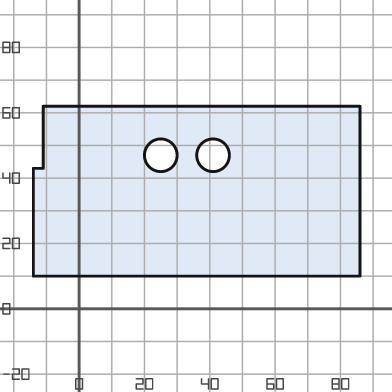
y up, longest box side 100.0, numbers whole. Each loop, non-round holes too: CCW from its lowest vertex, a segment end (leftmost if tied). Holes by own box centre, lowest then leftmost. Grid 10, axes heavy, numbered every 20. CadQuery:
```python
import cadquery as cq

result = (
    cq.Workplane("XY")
    .moveTo(-14.0, 10.0)
    .lineTo(86.0, 10.0)
    .lineTo(86.0, 62.0)
    .lineTo(-11.0, 62.0)
    .lineTo(-11.0, 43.0)
    .lineTo(-14.0, 43.0)
    .close()
    .moveTo(25.0, 47.0)
    .circle(5.0)
    .moveTo(41.0, 47.0)
    .circle(5.0)
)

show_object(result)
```